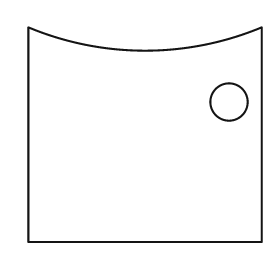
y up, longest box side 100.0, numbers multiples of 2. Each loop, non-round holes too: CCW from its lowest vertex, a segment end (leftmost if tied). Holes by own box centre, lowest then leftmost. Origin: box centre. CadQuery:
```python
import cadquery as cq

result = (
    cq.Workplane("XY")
    .moveTo(-50.0, -46.0)
    .lineTo(50.0, -46.0)
    .lineTo(50.0, 46.0)
    .threePointArc((0.0, 36.0), (-50.0, 46.0))
    .close()
    .moveTo(36.0, 14.0)
    .circle(8.0)
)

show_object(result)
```